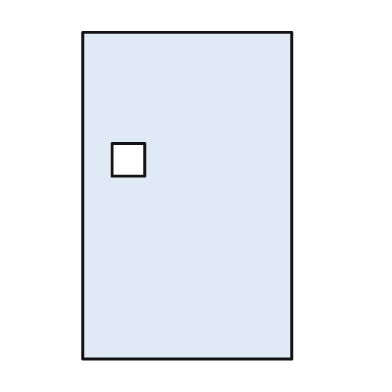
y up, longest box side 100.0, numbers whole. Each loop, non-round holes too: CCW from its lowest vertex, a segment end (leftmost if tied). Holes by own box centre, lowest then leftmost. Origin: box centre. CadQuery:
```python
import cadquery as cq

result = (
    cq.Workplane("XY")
    .moveTo(-32.0, -50.0)
    .lineTo(32.0, -50.0)
    .lineTo(32.0, 50.0)
    .lineTo(-32.0, 50.0)
    .close()
    .moveTo(-23.0, 6.0)
    .lineTo(-13.0, 6.0)
    .lineTo(-13.0, 16.0)
    .lineTo(-23.0, 16.0)
    .close()
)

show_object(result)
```